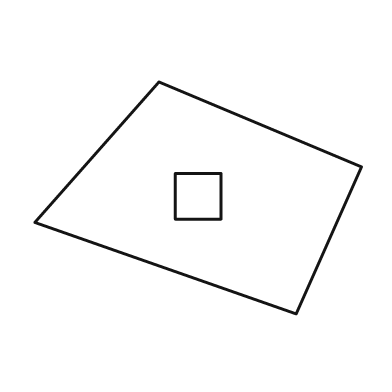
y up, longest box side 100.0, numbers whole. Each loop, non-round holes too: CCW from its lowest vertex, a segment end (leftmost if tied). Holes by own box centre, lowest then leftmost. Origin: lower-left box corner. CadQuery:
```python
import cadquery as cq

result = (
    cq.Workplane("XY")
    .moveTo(80.0, 0.0)
    .lineTo(100.0, 45.0)
    .lineTo(38.0, 71.0)
    .lineTo(0.0, 28.0)
    .close()
    .moveTo(43.0, 29.0)
    .lineTo(57.0, 29.0)
    .lineTo(57.0, 43.0)
    .lineTo(43.0, 43.0)
    .close()
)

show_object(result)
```